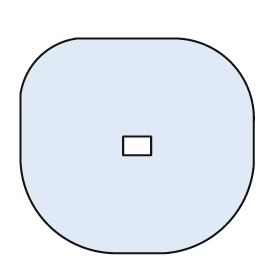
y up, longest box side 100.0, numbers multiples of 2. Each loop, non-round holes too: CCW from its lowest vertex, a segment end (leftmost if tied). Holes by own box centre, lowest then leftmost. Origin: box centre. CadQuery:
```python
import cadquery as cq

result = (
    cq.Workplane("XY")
    .moveTo(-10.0, -46.0)
    .lineTo(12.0, -46.0)
    .threePointArc((38.0, -34.0), (50.0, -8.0))
    .lineTo(50.0, 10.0)
    .threePointArc((40.0, 36.0), (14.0, 46.0))
    .lineTo(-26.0, 46.0)
    .threePointArc((-42.0, 38.0), (-50.0, 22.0))
    .lineTo(-50.0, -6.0)
    .threePointArc((-38.0, -34.0), (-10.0, -46.0))
    .close()
    .moveTo(-6.0, -4.0)
    .lineTo(6.0, -4.0)
    .lineTo(6.0, 4.0)
    .lineTo(-6.0, 4.0)
    .close()
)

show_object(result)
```